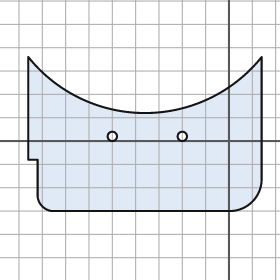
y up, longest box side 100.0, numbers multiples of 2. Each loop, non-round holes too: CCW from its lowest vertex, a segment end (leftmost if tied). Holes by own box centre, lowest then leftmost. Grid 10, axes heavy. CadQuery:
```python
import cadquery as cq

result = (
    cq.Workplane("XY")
    .moveTo(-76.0, -30.0)
    .lineTo(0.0, -30.0)
    .threePointArc((10.0, -26.0), (14.0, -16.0))
    .lineTo(14.0, 36.0)
    .threePointArc((-36.0, 12.0), (-86.0, 36.0))
    .lineTo(-86.0, -8.0)
    .lineTo(-82.0, -8.0)
    .lineTo(-82.0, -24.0)
    .threePointArc((-80.0, -28.0), (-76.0, -30.0))
    .close()
    .moveTo(-50.0, 2.0)
    .circle(2.0)
    .moveTo(-20.0, 2.0)
    .circle(2.0)
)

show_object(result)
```